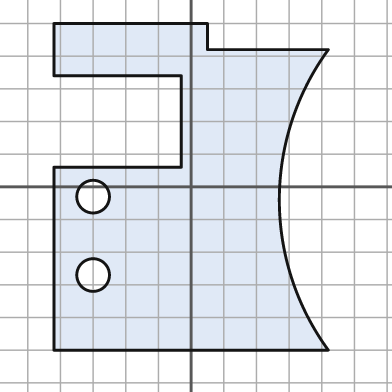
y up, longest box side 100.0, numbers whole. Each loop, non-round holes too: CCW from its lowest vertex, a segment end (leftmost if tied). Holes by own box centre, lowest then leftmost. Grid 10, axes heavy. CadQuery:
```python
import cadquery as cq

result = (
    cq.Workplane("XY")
    .moveTo(-42.0, -50.0)
    .lineTo(42.0, -50.0)
    .threePointArc((27.0, -4.0), (42.0, 42.0))
    .lineTo(5.0, 42.0)
    .lineTo(5.0, 50.0)
    .lineTo(-42.0, 50.0)
    .lineTo(-42.0, 34.0)
    .lineTo(-3.0, 34.0)
    .lineTo(-3.0, 6.0)
    .lineTo(-42.0, 6.0)
    .close()
    .moveTo(-30.0, -27.0)
    .circle(5.0)
    .moveTo(-30.0, -3.0)
    .circle(5.0)
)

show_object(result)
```